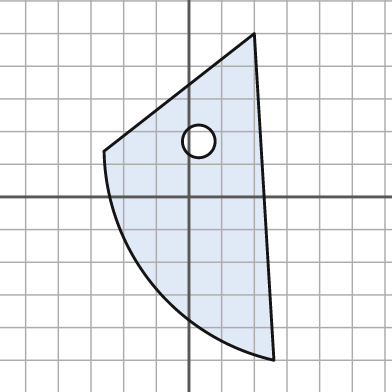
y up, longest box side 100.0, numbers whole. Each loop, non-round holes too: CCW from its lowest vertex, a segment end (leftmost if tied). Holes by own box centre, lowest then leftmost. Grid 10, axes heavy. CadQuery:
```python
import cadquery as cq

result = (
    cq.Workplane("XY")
    .moveTo(26.0, -50.0)
    .lineTo(20.0, 50.0)
    .lineTo(-26.0, 14.0)
    .threePointArc((-11.0, -27.0), (26.0, -50.0))
    .close()
    .moveTo(3.0, 17.0)
    .circle(5.0)
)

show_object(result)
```